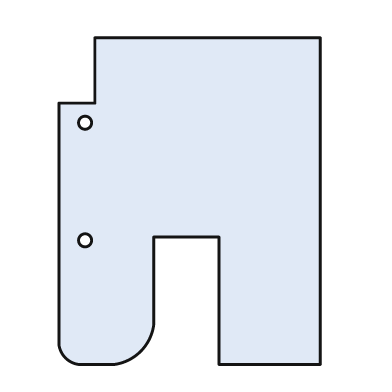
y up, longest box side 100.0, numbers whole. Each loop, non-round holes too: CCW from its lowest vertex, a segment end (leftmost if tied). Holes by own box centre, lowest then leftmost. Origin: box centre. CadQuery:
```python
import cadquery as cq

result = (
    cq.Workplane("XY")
    .moveTo(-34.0, -50.0)
    .lineTo(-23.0, -50.0)
    .threePointArc((-15.0, -46.0), (-11.0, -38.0))
    .lineTo(-11.0, -11.0)
    .lineTo(9.0, -11.0)
    .lineTo(9.0, -50.0)
    .lineTo(40.0, -50.0)
    .lineTo(40.0, 50.0)
    .lineTo(-29.0, 50.0)
    .lineTo(-29.0, 30.0)
    .lineTo(-40.0, 30.0)
    .lineTo(-40.0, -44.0)
    .threePointArc((-38.0, -48.0), (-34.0, -50.0))
    .close()
    .moveTo(-32.0, -12.0)
    .circle(2.0)
    .moveTo(-32.0, 24.0)
    .circle(2.0)
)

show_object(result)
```